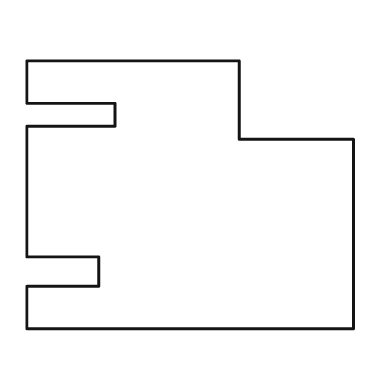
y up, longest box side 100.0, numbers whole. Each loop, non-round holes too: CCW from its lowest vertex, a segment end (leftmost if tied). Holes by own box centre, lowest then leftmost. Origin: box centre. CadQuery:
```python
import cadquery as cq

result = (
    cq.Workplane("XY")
    .moveTo(-50.0, -41.0)
    .lineTo(50.0, -41.0)
    .lineTo(50.0, 17.0)
    .lineTo(15.0, 17.0)
    .lineTo(15.0, 41.0)
    .lineTo(-50.0, 41.0)
    .lineTo(-50.0, 28.0)
    .lineTo(-23.0, 28.0)
    .lineTo(-23.0, 21.0)
    .lineTo(-50.0, 21.0)
    .lineTo(-50.0, -19.0)
    .lineTo(-28.0, -19.0)
    .lineTo(-28.0, -28.0)
    .lineTo(-50.0, -28.0)
    .close()
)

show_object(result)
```